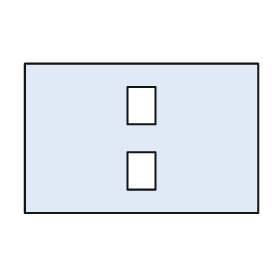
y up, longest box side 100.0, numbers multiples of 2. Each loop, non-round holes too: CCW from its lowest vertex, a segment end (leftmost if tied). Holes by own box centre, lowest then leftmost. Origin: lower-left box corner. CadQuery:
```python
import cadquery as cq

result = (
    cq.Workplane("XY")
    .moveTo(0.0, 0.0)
    .lineTo(100.0, 0.0)
    .lineTo(100.0, 64.0)
    .lineTo(0.0, 64.0)
    .close()
    .moveTo(44.0, 10.0)
    .lineTo(56.0, 10.0)
    .lineTo(56.0, 26.0)
    .lineTo(44.0, 26.0)
    .close()
    .moveTo(44.0, 38.0)
    .lineTo(56.0, 38.0)
    .lineTo(56.0, 54.0)
    .lineTo(44.0, 54.0)
    .close()
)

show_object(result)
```